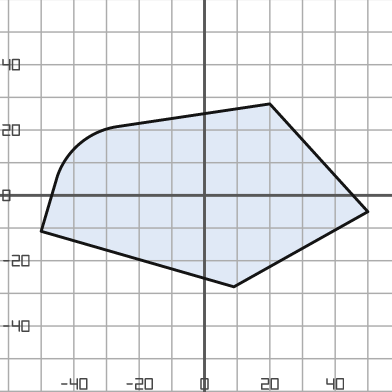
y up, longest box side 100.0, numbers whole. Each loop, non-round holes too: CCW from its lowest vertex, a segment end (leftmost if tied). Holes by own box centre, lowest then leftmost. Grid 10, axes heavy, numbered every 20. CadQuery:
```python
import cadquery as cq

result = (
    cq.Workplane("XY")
    .moveTo(9.0, -28.0)
    .lineTo(50.0, -5.0)
    .lineTo(20.0, 28.0)
    .lineTo(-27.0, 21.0)
    .threePointArc((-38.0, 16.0), (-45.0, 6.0))
    .lineTo(-50.0, -11.0)
    .close()
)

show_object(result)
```